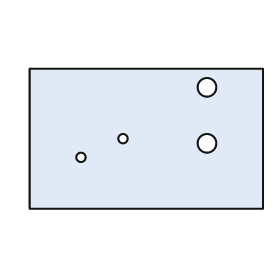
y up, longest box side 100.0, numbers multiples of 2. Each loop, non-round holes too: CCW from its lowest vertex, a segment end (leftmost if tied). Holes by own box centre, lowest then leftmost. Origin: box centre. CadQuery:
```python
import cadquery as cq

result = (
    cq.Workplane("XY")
    .moveTo(-50.0, -30.0)
    .lineTo(50.0, -30.0)
    .lineTo(50.0, 30.0)
    .lineTo(-50.0, 30.0)
    .close()
    .moveTo(-28.0, -8.0)
    .circle(2.0)
    .moveTo(26.0, -2.0)
    .circle(4.0)
    .moveTo(-10.0, 0.0)
    .circle(2.0)
    .moveTo(26.0, 22.0)
    .circle(4.0)
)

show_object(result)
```